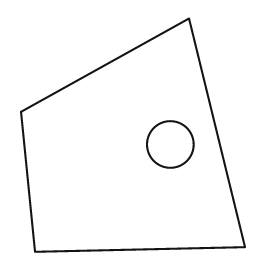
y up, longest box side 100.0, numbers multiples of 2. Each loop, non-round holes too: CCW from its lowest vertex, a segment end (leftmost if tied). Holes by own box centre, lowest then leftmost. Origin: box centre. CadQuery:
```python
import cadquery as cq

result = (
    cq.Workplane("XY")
    .moveTo(-42.0, -50.0)
    .lineTo(48.0, -48.0)
    .lineTo(24.0, 50.0)
    .lineTo(-48.0, 10.0)
    .close()
    .moveTo(16.0, -4.0)
    .circle(10.0)
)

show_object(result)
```